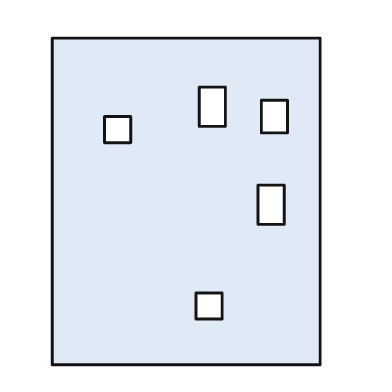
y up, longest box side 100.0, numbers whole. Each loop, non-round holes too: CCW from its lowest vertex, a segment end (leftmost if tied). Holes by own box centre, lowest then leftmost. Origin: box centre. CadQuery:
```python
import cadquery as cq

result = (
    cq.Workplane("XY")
    .moveTo(-41.0, -50.0)
    .lineTo(41.0, -50.0)
    .lineTo(41.0, 50.0)
    .lineTo(-41.0, 50.0)
    .close()
    .moveTo(3.0, -36.0)
    .lineTo(11.0, -36.0)
    .lineTo(11.0, -28.0)
    .lineTo(3.0, -28.0)
    .close()
    .moveTo(22.0, -7.0)
    .lineTo(30.0, -7.0)
    .lineTo(30.0, 5.0)
    .lineTo(22.0, 5.0)
    .close()
    .moveTo(-25.0, 18.0)
    .lineTo(-17.0, 18.0)
    .lineTo(-17.0, 26.0)
    .lineTo(-25.0, 26.0)
    .close()
    .moveTo(23.0, 21.0)
    .lineTo(31.0, 21.0)
    .lineTo(31.0, 31.0)
    .lineTo(23.0, 31.0)
    .close()
    .moveTo(4.0, 23.0)
    .lineTo(12.0, 23.0)
    .lineTo(12.0, 35.0)
    .lineTo(4.0, 35.0)
    .close()
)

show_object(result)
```